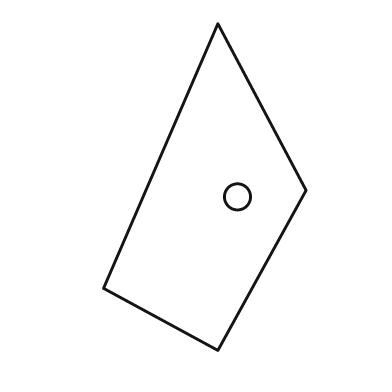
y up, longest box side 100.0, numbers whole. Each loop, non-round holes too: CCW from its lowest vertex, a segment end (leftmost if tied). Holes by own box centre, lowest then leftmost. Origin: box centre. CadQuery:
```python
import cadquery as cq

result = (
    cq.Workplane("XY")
    .moveTo(4.0, -50.0)
    .lineTo(31.0, -1.0)
    .lineTo(4.0, 50.0)
    .lineTo(-31.0, -31.0)
    .close()
    .moveTo(10.0, -3.0)
    .circle(4.0)
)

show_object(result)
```